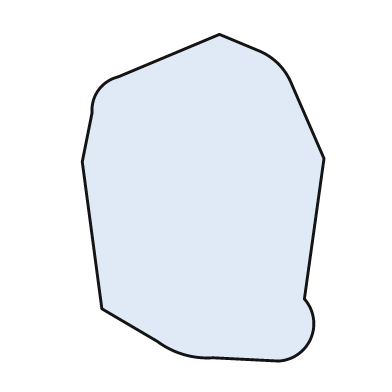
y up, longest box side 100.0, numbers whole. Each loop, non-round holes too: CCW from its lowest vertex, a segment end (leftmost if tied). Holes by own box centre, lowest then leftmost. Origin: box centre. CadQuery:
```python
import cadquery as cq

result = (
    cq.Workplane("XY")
    .moveTo(23.0, -50.0)
    .threePointArc((33.0, -43.0), (31.0, -31.0))
    .lineTo(37.0, 12.0)
    .lineTo(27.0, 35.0)
    .threePointArc((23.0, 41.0), (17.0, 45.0))
    .lineTo(5.0, 50.0)
    .lineTo(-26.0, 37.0)
    .threePointArc((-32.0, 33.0), (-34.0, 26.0))
    .lineTo(-37.0, 11.0)
    .lineTo(-31.0, -34.0)
    .lineTo(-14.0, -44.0)
    .threePointArc((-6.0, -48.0), (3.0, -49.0))
    .close()
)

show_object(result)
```